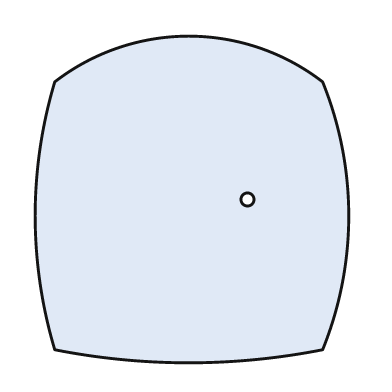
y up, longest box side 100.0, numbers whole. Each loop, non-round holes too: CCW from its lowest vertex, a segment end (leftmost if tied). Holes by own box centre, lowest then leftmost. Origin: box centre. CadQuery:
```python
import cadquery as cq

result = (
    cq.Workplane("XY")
    .moveTo(-42.0, -46.0)
    .threePointArc((-1.0, -50.0), (40.0, -46.0))
    .threePointArc((48.0, -5.0), (40.0, 36.0))
    .threePointArc((-1.0, 50.0), (-42.0, 36.0))
    .threePointArc((-48.0, -5.0), (-42.0, -46.0))
    .close()
    .moveTo(17.0, 0.0)
    .circle(2.0)
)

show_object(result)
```